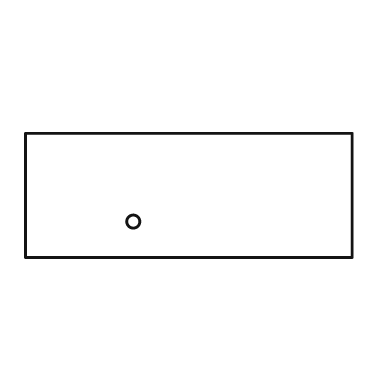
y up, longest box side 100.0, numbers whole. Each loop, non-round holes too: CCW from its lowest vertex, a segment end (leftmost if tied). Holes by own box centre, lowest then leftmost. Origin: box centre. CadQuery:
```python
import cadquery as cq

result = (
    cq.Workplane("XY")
    .moveTo(-50.0, -19.0)
    .lineTo(50.0, -19.0)
    .lineTo(50.0, 19.0)
    .lineTo(-50.0, 19.0)
    .close()
    .moveTo(-17.0, -8.0)
    .circle(2.0)
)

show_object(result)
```